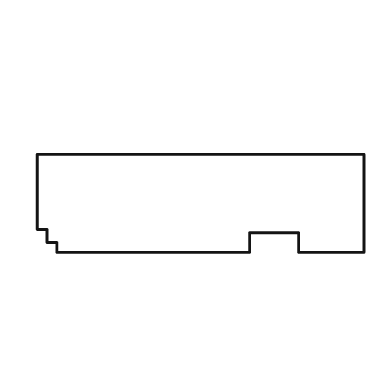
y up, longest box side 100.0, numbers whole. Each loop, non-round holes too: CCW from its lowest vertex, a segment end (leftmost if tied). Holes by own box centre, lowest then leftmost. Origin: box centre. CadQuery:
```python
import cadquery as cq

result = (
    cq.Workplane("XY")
    .moveTo(-44.0, -15.0)
    .lineTo(15.0, -15.0)
    .lineTo(15.0, -9.0)
    .lineTo(30.0, -9.0)
    .lineTo(30.0, -15.0)
    .lineTo(50.0, -15.0)
    .lineTo(50.0, 15.0)
    .lineTo(-50.0, 15.0)
    .lineTo(-50.0, -8.0)
    .lineTo(-47.0, -8.0)
    .lineTo(-47.0, -12.0)
    .lineTo(-44.0, -12.0)
    .close()
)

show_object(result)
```